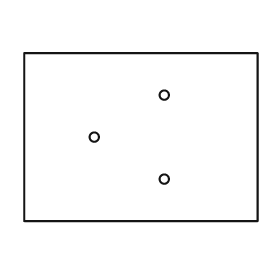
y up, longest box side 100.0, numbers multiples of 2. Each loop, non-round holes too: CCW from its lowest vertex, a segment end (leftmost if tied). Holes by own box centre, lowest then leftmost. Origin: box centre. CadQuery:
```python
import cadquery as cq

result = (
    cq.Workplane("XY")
    .moveTo(-50.0, -36.0)
    .lineTo(50.0, -36.0)
    .lineTo(50.0, 36.0)
    .lineTo(-50.0, 36.0)
    .close()
    .moveTo(10.0, -18.0)
    .circle(2.0)
    .moveTo(-20.0, 0.0)
    .circle(2.0)
    .moveTo(10.0, 18.0)
    .circle(2.0)
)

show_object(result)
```